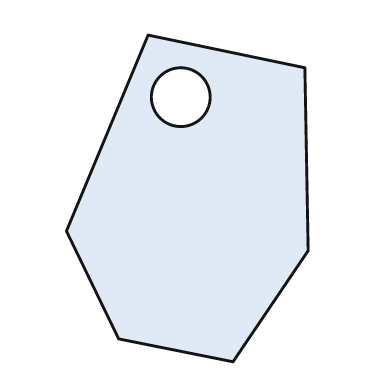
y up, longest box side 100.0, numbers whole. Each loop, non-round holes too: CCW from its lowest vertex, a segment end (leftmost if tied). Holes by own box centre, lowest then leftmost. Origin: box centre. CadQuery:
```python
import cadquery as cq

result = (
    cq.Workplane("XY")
    .moveTo(14.0, -50.0)
    .lineTo(37.0, -16.0)
    .lineTo(36.0, 40.0)
    .lineTo(-12.0, 50.0)
    .lineTo(-37.0, -10.0)
    .lineTo(-21.0, -43.0)
    .close()
    .moveTo(-2.0, 31.0)
    .circle(9.0)
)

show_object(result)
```